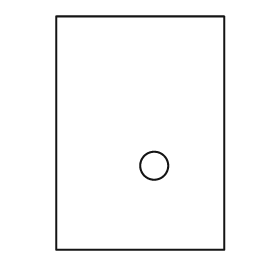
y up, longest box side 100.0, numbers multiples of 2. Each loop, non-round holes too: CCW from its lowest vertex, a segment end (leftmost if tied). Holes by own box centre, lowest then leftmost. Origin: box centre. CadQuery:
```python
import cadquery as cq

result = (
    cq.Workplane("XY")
    .moveTo(-36.0, -50.0)
    .lineTo(36.0, -50.0)
    .lineTo(36.0, 50.0)
    .lineTo(-36.0, 50.0)
    .close()
    .moveTo(6.0, -14.0)
    .circle(6.0)
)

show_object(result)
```